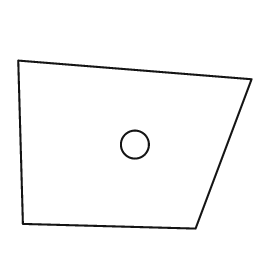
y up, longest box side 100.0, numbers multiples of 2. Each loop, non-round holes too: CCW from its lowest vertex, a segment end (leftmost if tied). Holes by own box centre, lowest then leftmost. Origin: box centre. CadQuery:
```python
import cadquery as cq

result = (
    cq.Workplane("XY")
    .moveTo(26.0, -36.0)
    .lineTo(50.0, 28.0)
    .lineTo(-50.0, 36.0)
    .lineTo(-48.0, -34.0)
    .close()
    .moveTo(0.0, 0.0)
    .circle(6.0)
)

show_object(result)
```